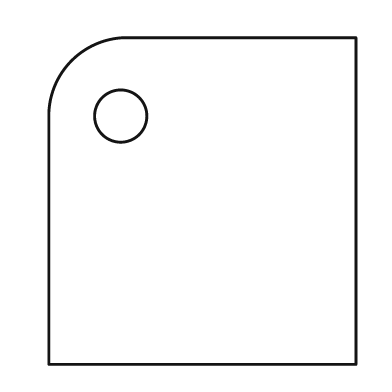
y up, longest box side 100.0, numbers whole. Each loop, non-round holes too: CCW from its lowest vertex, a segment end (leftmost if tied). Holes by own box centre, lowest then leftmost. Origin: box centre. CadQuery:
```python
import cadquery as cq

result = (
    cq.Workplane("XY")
    .moveTo(-47.0, -50.0)
    .lineTo(47.0, -50.0)
    .lineTo(47.0, 50.0)
    .lineTo(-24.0, 50.0)
    .threePointArc((-40.0, 43.0), (-47.0, 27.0))
    .close()
    .moveTo(-25.0, 26.0)
    .circle(8.0)
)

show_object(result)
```